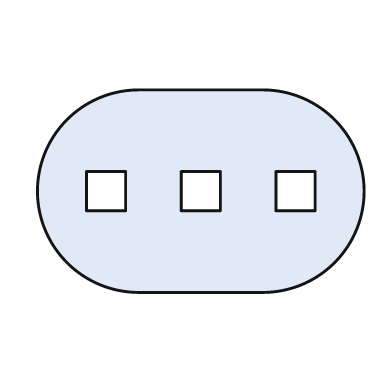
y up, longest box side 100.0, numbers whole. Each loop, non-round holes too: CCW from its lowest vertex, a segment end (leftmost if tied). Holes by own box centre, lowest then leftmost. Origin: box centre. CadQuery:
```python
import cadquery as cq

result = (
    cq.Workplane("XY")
    .moveTo(-19.0, -31.0)
    .lineTo(19.0, -31.0)
    .threePointArc((50.0, 0.0), (19.0, 31.0))
    .lineTo(-19.0, 31.0)
    .threePointArc((-50.0, 0.0), (-19.0, -31.0))
    .close()
    .moveTo(-35.0, -6.0)
    .lineTo(-23.0, -6.0)
    .lineTo(-23.0, 6.0)
    .lineTo(-35.0, 6.0)
    .close()
    .moveTo(-6.0, -6.0)
    .lineTo(6.0, -6.0)
    .lineTo(6.0, 6.0)
    .lineTo(-6.0, 6.0)
    .close()
    .moveTo(23.0, -6.0)
    .lineTo(35.0, -6.0)
    .lineTo(35.0, 6.0)
    .lineTo(23.0, 6.0)
    .close()
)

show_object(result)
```